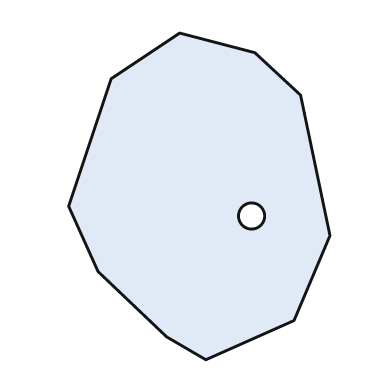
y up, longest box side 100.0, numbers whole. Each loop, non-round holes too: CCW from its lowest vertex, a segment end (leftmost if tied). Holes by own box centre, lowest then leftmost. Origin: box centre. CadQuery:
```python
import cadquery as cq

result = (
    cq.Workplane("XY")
    .moveTo(2.0, -50.0)
    .lineTo(29.0, -38.0)
    .lineTo(40.0, -12.0)
    .lineTo(31.0, 31.0)
    .lineTo(17.0, 44.0)
    .lineTo(-6.0, 50.0)
    .lineTo(-27.0, 36.0)
    .lineTo(-40.0, -3.0)
    .lineTo(-31.0, -23.0)
    .lineTo(-10.0, -43.0)
    .close()
    .moveTo(16.0, -6.0)
    .circle(4.0)
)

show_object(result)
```